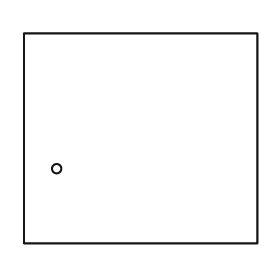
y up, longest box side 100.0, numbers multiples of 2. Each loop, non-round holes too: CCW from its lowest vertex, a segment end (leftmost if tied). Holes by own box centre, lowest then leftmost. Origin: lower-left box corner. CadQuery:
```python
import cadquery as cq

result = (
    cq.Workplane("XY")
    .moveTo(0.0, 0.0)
    .lineTo(100.0, 0.0)
    .lineTo(100.0, 90.0)
    .lineTo(0.0, 90.0)
    .close()
    .moveTo(14.0, 32.0)
    .circle(2.0)
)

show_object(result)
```